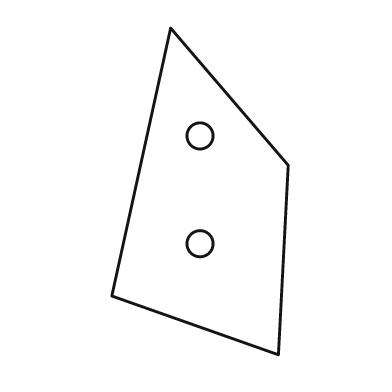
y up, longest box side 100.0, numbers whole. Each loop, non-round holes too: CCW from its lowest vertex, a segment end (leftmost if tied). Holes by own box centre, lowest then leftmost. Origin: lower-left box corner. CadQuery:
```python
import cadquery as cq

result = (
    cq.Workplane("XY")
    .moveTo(51.0, 0.0)
    .lineTo(54.0, 58.0)
    .lineTo(18.0, 100.0)
    .lineTo(0.0, 18.0)
    .close()
    .moveTo(27.0, 34.0)
    .circle(4.0)
    .moveTo(27.0, 67.0)
    .circle(4.0)
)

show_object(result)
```